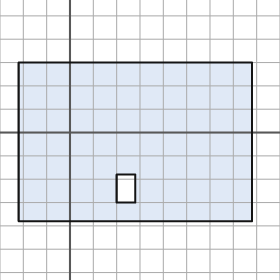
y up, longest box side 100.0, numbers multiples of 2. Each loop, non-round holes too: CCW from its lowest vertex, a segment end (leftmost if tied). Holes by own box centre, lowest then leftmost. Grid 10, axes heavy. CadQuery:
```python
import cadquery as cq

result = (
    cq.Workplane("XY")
    .moveTo(-22.0, -38.0)
    .lineTo(78.0, -38.0)
    .lineTo(78.0, 30.0)
    .lineTo(-22.0, 30.0)
    .close()
    .moveTo(20.0, -30.0)
    .lineTo(28.0, -30.0)
    .lineTo(28.0, -18.0)
    .lineTo(20.0, -18.0)
    .close()
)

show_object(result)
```